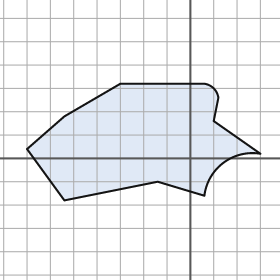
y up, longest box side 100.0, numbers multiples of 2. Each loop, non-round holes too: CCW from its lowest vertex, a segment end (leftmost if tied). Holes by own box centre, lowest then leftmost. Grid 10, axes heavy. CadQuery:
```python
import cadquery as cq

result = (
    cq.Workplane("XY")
    .moveTo(-54.0, -18.0)
    .lineTo(-14.0, -10.0)
    .lineTo(6.0, -16.0)
    .threePointArc((14.0, -2.0), (30.0, 2.0))
    .lineTo(10.0, 16.0)
    .lineTo(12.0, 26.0)
    .threePointArc((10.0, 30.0), (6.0, 32.0))
    .lineTo(-30.0, 32.0)
    .lineTo(-54.0, 18.0)
    .lineTo(-70.0, 4.0)
    .close()
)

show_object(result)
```